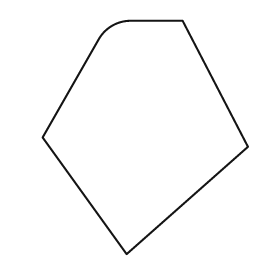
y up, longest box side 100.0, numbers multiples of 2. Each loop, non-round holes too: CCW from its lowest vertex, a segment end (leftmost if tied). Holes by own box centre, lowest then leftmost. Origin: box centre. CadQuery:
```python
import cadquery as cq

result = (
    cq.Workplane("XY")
    .moveTo(-8.0, -50.0)
    .lineTo(44.0, -4.0)
    .lineTo(16.0, 50.0)
    .lineTo(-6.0, 50.0)
    .threePointArc((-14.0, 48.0), (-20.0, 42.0))
    .lineTo(-44.0, 0.0)
    .close()
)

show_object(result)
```